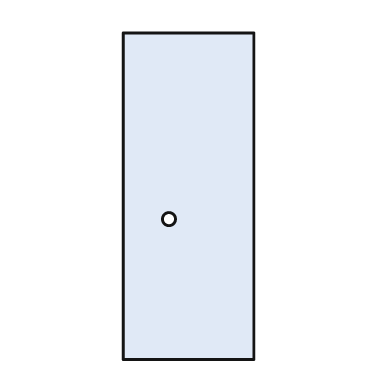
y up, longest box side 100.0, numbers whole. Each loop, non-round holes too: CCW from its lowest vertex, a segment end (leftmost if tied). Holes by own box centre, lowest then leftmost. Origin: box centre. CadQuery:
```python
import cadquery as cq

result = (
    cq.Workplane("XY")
    .moveTo(-20.0, -50.0)
    .lineTo(20.0, -50.0)
    .lineTo(20.0, 50.0)
    .lineTo(-20.0, 50.0)
    .close()
    .moveTo(-6.0, -7.0)
    .circle(2.0)
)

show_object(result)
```